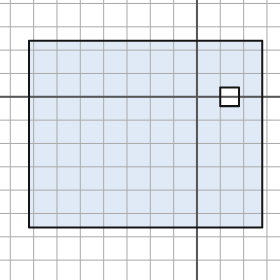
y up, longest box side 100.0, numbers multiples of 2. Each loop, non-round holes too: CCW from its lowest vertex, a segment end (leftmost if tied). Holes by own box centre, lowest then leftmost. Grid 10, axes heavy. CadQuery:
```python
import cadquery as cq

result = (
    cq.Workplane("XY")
    .moveTo(-72.0, -56.0)
    .lineTo(28.0, -56.0)
    .lineTo(28.0, 24.0)
    .lineTo(-72.0, 24.0)
    .close()
    .moveTo(10.0, -4.0)
    .lineTo(18.0, -4.0)
    .lineTo(18.0, 4.0)
    .lineTo(10.0, 4.0)
    .close()
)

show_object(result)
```